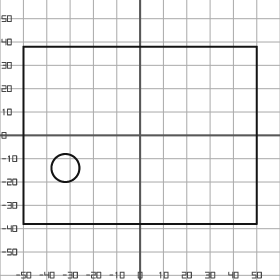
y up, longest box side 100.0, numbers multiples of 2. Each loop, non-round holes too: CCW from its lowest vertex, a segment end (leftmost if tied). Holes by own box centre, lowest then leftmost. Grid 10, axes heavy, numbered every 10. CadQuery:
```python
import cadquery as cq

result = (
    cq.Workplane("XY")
    .moveTo(-50.0, -38.0)
    .lineTo(50.0, -38.0)
    .lineTo(50.0, 38.0)
    .lineTo(-50.0, 38.0)
    .close()
    .moveTo(-32.0, -14.0)
    .circle(6.0)
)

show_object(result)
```